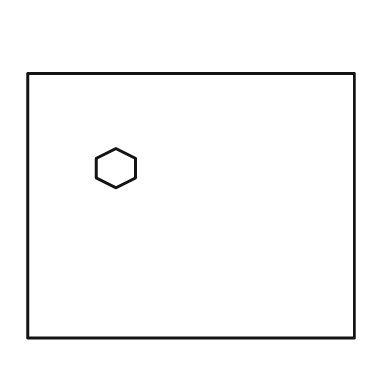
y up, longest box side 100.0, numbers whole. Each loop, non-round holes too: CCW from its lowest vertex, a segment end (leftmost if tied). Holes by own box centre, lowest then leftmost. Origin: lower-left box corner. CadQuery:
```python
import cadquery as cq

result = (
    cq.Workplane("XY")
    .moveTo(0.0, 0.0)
    .lineTo(100.0, 0.0)
    .lineTo(100.0, 81.0)
    .lineTo(0.0, 81.0)
    .close()
    .moveTo(27.0, 46.0)
    .lineTo(33.0, 49.0)
    .lineTo(33.0, 55.0)
    .lineTo(27.0, 58.0)
    .lineTo(21.0, 55.0)
    .lineTo(21.0, 49.0)
    .close()
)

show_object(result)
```